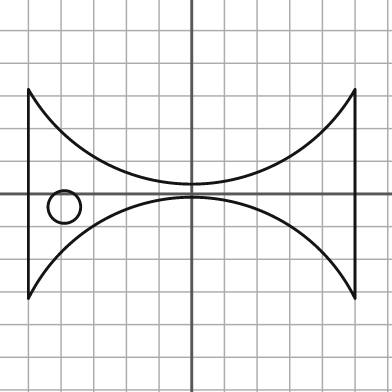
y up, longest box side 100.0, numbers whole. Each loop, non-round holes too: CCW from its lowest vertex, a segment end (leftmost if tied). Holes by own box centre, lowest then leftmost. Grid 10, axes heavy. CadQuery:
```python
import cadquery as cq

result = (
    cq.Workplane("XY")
    .moveTo(-50.0, -32.0)
    .threePointArc((0.0, -1.0), (50.0, -32.0))
    .lineTo(50.0, 32.0)
    .threePointArc((0.0, 3.0), (-50.0, 32.0))
    .close()
    .moveTo(-39.0, -4.0)
    .circle(5.0)
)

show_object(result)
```